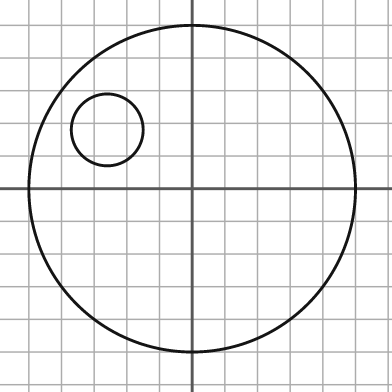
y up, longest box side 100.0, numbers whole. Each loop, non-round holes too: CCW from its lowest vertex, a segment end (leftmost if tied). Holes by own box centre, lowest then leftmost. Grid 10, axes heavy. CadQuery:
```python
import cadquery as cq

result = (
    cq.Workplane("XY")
    .moveTo(0.0, 0.0)
    .circle(50.0)
    .moveTo(-26.0, 18.0)
    .circle(11.0)
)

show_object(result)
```